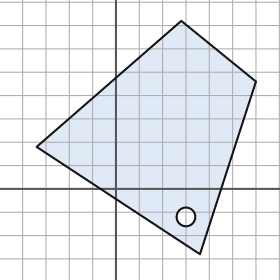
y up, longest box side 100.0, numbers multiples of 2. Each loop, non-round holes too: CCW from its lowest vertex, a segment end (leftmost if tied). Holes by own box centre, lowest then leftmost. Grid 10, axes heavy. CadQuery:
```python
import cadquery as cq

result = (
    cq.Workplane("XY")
    .moveTo(36.0, -28.0)
    .lineTo(60.0, 46.0)
    .lineTo(28.0, 72.0)
    .lineTo(-34.0, 18.0)
    .close()
    .moveTo(30.0, -12.0)
    .circle(4.0)
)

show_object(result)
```